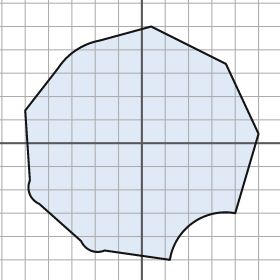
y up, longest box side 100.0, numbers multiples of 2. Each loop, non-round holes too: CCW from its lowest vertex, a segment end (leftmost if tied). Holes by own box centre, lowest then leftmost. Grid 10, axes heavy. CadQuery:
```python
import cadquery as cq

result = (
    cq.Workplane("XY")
    .moveTo(12.0, -50.0)
    .threePointArc((22.0, -34.0), (40.0, -30.0))
    .lineTo(50.0, 4.0)
    .lineTo(36.0, 34.0)
    .lineTo(4.0, 50.0)
    .lineTo(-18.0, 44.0)
    .threePointArc((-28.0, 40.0), (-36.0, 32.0))
    .lineTo(-50.0, 14.0)
    .lineTo(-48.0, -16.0)
    .threePointArc((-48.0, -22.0), (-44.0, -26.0))
    .lineTo(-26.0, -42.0)
    .threePointArc((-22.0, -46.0), (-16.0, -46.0))
    .close()
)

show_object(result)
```